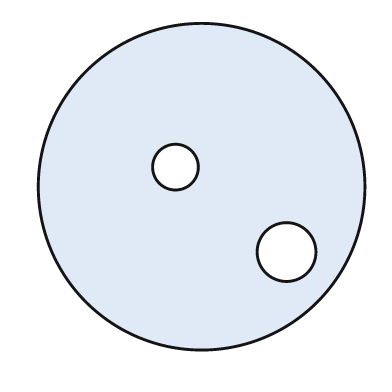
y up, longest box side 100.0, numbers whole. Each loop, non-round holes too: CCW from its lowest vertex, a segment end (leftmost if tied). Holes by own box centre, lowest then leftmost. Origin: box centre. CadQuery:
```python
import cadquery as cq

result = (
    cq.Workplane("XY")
    .moveTo(0.0, 0.0)
    .circle(50.0)
    .moveTo(26.0, -20.0)
    .circle(9.0)
    .moveTo(-8.0, 6.0)
    .circle(7.0)
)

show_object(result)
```